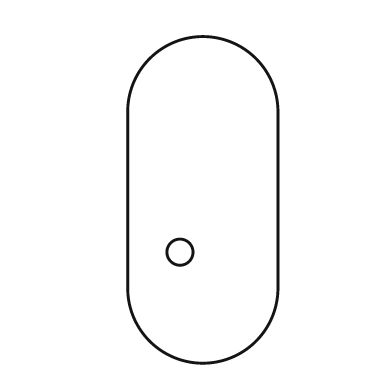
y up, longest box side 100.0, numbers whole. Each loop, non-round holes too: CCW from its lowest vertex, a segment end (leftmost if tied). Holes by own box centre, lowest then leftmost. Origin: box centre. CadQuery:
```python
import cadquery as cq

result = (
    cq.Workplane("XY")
    .moveTo(-23.0, -27.0)
    .threePointArc((0.0, -50.0), (23.0, -27.0))
    .lineTo(23.0, 27.0)
    .threePointArc((0.0, 50.0), (-23.0, 27.0))
    .close()
    .moveTo(-7.0, -16.0)
    .circle(4.0)
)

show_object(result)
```